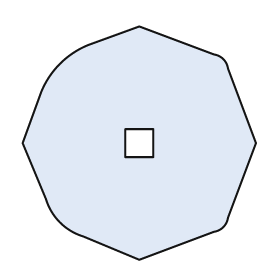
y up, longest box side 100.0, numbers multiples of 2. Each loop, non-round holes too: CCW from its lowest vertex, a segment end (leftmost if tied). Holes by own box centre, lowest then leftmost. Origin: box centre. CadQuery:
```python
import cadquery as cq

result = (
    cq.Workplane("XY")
    .moveTo(0.0, -50.0)
    .lineTo(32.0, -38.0)
    .threePointArc((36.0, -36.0), (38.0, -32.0))
    .lineTo(50.0, 0.0)
    .lineTo(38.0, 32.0)
    .threePointArc((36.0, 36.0), (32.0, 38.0))
    .lineTo(0.0, 50.0)
    .lineTo(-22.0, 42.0)
    .threePointArc((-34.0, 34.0), (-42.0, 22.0))
    .lineTo(-50.0, 0.0)
    .lineTo(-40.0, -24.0)
    .threePointArc((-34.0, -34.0), (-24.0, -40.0))
    .close()
    .moveTo(-6.0, -6.0)
    .lineTo(6.0, -6.0)
    .lineTo(6.0, 6.0)
    .lineTo(-6.0, 6.0)
    .close()
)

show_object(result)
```